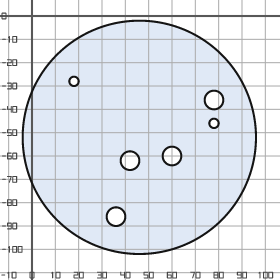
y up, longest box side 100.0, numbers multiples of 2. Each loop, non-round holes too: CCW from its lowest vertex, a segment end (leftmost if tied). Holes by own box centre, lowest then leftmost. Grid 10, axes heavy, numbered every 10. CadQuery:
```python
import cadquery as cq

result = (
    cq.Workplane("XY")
    .moveTo(46.0, -52.0)
    .circle(50.0)
    .moveTo(36.0, -86.0)
    .circle(4.0)
    .moveTo(42.0, -62.0)
    .circle(4.0)
    .moveTo(60.0, -60.0)
    .circle(4.0)
    .moveTo(78.0, -46.0)
    .circle(2.0)
    .moveTo(78.0, -36.0)
    .circle(4.0)
    .moveTo(18.0, -28.0)
    .circle(2.0)
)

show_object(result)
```